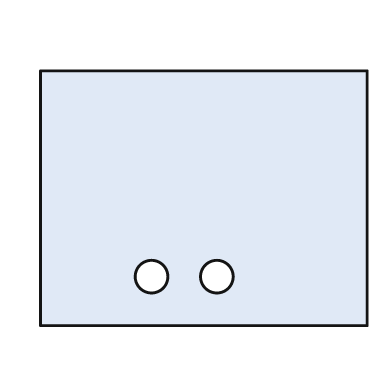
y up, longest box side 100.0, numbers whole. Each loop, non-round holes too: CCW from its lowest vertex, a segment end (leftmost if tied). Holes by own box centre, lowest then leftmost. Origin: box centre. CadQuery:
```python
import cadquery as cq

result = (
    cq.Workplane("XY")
    .moveTo(-50.0, -39.0)
    .lineTo(50.0, -39.0)
    .lineTo(50.0, 39.0)
    .lineTo(-50.0, 39.0)
    .close()
    .moveTo(-16.0, -24.0)
    .circle(5.0)
    .moveTo(4.0, -24.0)
    .circle(5.0)
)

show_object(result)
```